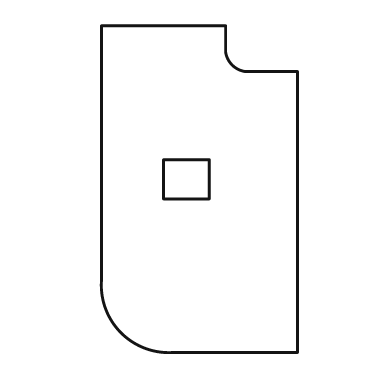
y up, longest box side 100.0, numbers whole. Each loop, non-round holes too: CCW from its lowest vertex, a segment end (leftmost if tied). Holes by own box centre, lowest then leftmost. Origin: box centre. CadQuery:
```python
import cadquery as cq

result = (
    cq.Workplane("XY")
    .moveTo(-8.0, -50.0)
    .lineTo(30.0, -50.0)
    .lineTo(30.0, 36.0)
    .lineTo(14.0, 36.0)
    .threePointArc((10.0, 38.0), (8.0, 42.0))
    .lineTo(8.0, 50.0)
    .lineTo(-30.0, 50.0)
    .lineTo(-30.0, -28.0)
    .threePointArc((-24.0, -44.0), (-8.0, -50.0))
    .close()
    .moveTo(-11.0, -3.0)
    .lineTo(3.0, -3.0)
    .lineTo(3.0, 9.0)
    .lineTo(-11.0, 9.0)
    .close()
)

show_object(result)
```